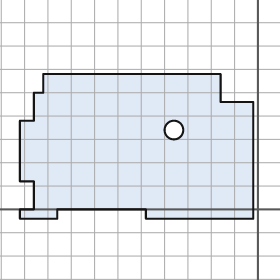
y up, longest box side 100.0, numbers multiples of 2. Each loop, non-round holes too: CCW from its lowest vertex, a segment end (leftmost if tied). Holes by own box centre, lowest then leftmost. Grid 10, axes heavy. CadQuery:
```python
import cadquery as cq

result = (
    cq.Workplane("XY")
    .moveTo(-102.0, -4.0)
    .lineTo(-86.0, -4.0)
    .lineTo(-86.0, 0.0)
    .lineTo(-48.0, 0.0)
    .lineTo(-48.0, -4.0)
    .lineTo(-2.0, -4.0)
    .lineTo(-2.0, 46.0)
    .lineTo(-16.0, 46.0)
    .lineTo(-16.0, 58.0)
    .lineTo(-92.0, 58.0)
    .lineTo(-92.0, 50.0)
    .lineTo(-96.0, 50.0)
    .lineTo(-96.0, 38.0)
    .lineTo(-102.0, 38.0)
    .lineTo(-102.0, 12.0)
    .lineTo(-96.0, 12.0)
    .lineTo(-96.0, 0.0)
    .lineTo(-102.0, 0.0)
    .close()
    .moveTo(-36.0, 34.0)
    .circle(4.0)
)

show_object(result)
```